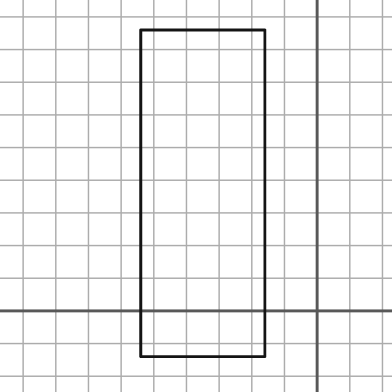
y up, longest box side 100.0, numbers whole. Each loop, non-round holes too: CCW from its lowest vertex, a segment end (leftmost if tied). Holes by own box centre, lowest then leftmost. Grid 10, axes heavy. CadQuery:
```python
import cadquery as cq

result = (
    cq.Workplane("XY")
    .moveTo(-54.0, -14.0)
    .lineTo(-16.0, -14.0)
    .lineTo(-16.0, 86.0)
    .lineTo(-54.0, 86.0)
    .close()
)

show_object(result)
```